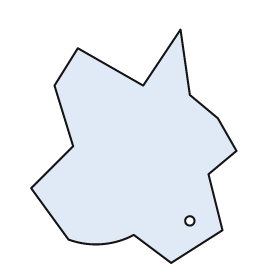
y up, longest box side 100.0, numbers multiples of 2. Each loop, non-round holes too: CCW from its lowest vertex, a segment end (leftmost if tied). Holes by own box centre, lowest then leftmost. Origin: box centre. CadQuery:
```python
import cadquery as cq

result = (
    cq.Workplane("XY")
    .moveTo(16.0, -50.0)
    .lineTo(38.0, -36.0)
    .lineTo(32.0, -12.0)
    .lineTo(44.0, -2.0)
    .lineTo(36.0, 12.0)
    .lineTo(24.0, 22.0)
    .lineTo(20.0, 50.0)
    .lineTo(4.0, 26.0)
    .lineTo(-24.0, 42.0)
    .lineTo(-34.0, 26.0)
    .lineTo(-26.0, 0.0)
    .lineTo(-44.0, -18.0)
    .lineTo(-28.0, -40.0)
    .threePointArc((-14.0, -42.0), (0.0, -38.0))
    .close()
    .moveTo(24.0, -32.0)
    .circle(2.0)
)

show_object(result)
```